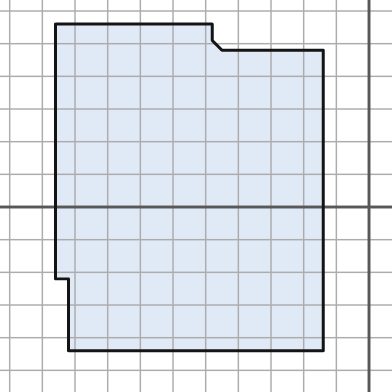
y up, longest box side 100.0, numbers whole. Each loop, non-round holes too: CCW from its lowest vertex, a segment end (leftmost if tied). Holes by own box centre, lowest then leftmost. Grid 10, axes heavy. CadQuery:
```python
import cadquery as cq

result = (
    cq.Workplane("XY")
    .moveTo(-92.0, -44.0)
    .lineTo(-14.0, -44.0)
    .lineTo(-14.0, 48.0)
    .lineTo(-45.0, 48.0)
    .lineTo(-48.0, 51.0)
    .lineTo(-48.0, 56.0)
    .lineTo(-96.0, 56.0)
    .lineTo(-96.0, -22.0)
    .lineTo(-92.0, -22.0)
    .close()
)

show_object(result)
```